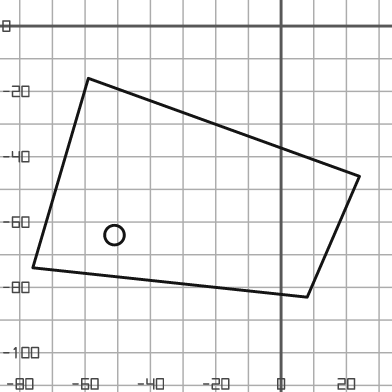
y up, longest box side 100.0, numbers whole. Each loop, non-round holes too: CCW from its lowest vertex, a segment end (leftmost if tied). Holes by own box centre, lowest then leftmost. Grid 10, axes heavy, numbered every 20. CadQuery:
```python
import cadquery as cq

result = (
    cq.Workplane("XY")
    .moveTo(8.0, -83.0)
    .lineTo(24.0, -46.0)
    .lineTo(-59.0, -16.0)
    .lineTo(-76.0, -74.0)
    .close()
    .moveTo(-51.0, -64.0)
    .circle(3.0)
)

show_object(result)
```